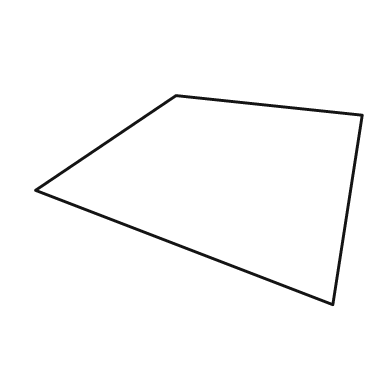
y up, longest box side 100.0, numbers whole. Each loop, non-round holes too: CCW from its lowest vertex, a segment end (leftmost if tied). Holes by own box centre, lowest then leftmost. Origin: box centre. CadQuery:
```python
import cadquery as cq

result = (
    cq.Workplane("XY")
    .moveTo(41.0, -32.0)
    .lineTo(50.0, 26.0)
    .lineTo(-7.0, 32.0)
    .lineTo(-50.0, 3.0)
    .close()
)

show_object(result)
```